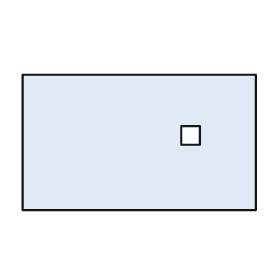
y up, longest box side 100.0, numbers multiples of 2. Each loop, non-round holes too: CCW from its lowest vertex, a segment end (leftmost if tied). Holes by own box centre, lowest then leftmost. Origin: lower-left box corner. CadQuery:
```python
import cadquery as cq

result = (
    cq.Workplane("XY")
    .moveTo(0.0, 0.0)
    .lineTo(100.0, 0.0)
    .lineTo(100.0, 58.0)
    .lineTo(0.0, 58.0)
    .close()
    .moveTo(68.0, 28.0)
    .lineTo(76.0, 28.0)
    .lineTo(76.0, 36.0)
    .lineTo(68.0, 36.0)
    .close()
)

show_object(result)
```